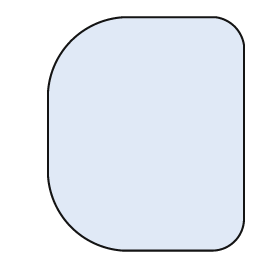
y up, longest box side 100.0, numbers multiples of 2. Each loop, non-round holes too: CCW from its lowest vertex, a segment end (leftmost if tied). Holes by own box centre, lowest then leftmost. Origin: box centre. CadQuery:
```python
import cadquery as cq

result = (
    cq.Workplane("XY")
    .moveTo(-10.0, -50.0)
    .lineTo(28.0, -50.0)
    .threePointArc((38.0, -46.0), (42.0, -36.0))
    .lineTo(42.0, 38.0)
    .threePointArc((38.0, 46.0), (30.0, 50.0))
    .lineTo(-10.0, 50.0)
    .threePointArc((-32.0, 40.0), (-42.0, 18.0))
    .lineTo(-42.0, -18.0)
    .threePointArc((-32.0, -40.0), (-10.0, -50.0))
    .close()
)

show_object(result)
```